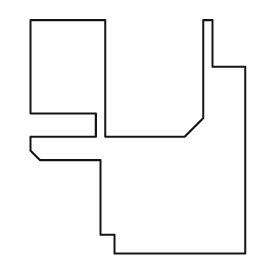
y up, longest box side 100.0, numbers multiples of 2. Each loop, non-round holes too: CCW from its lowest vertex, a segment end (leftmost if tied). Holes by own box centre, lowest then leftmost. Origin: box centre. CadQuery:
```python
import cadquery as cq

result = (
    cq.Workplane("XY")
    .moveTo(-10.0, -50.0)
    .lineTo(46.0, -50.0)
    .lineTo(46.0, 30.0)
    .lineTo(32.0, 30.0)
    .lineTo(32.0, 50.0)
    .lineTo(28.0, 50.0)
    .lineTo(28.0, 8.0)
    .lineTo(20.0, 0.0)
    .lineTo(-14.0, 0.0)
    .lineTo(-14.0, 50.0)
    .lineTo(-46.0, 50.0)
    .lineTo(-46.0, 10.0)
    .lineTo(-18.0, 10.0)
    .lineTo(-18.0, 0.0)
    .lineTo(-46.0, 0.0)
    .lineTo(-46.0, -6.0)
    .lineTo(-42.0, -10.0)
    .lineTo(-16.0, -10.0)
    .lineTo(-16.0, -42.0)
    .lineTo(-10.0, -42.0)
    .close()
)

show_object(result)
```